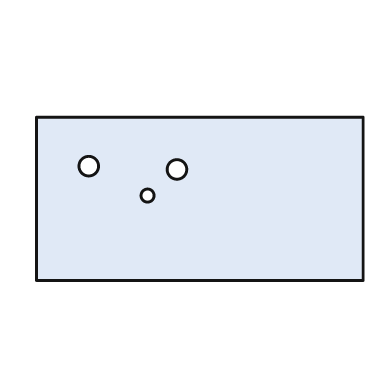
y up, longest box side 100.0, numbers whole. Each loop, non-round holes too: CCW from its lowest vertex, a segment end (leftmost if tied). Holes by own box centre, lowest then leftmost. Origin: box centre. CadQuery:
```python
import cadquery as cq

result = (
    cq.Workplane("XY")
    .moveTo(-50.0, -25.0)
    .lineTo(50.0, -25.0)
    .lineTo(50.0, 25.0)
    .lineTo(-50.0, 25.0)
    .close()
    .moveTo(-16.0, 1.0)
    .circle(2.0)
    .moveTo(-7.0, 9.0)
    .circle(3.0)
    .moveTo(-34.0, 10.0)
    .circle(3.0)
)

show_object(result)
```